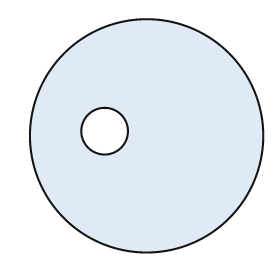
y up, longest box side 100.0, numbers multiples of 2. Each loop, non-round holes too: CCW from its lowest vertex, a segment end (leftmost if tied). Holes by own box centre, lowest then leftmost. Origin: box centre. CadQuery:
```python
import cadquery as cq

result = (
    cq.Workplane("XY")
    .moveTo(0.0, 0.0)
    .circle(50.0)
    .moveTo(-18.0, 2.0)
    .circle(10.0)
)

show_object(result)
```